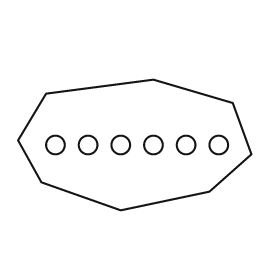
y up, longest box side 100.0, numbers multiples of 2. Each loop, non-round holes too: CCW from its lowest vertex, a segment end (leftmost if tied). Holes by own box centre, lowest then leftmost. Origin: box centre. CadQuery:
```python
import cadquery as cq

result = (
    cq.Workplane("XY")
    .moveTo(-6.0, -28.0)
    .lineTo(32.0, -20.0)
    .lineTo(50.0, -4.0)
    .lineTo(42.0, 18.0)
    .lineTo(8.0, 28.0)
    .lineTo(-38.0, 22.0)
    .lineTo(-50.0, 2.0)
    .lineTo(-40.0, -16.0)
    .close()
    .moveTo(-34.0, 0.0)
    .circle(4.0)
    .moveTo(-20.0, 0.0)
    .circle(4.0)
    .moveTo(-6.0, 0.0)
    .circle(4.0)
    .moveTo(8.0, 0.0)
    .circle(4.0)
    .moveTo(22.0, 0.0)
    .circle(4.0)
    .moveTo(36.0, 0.0)
    .circle(4.0)
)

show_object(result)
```